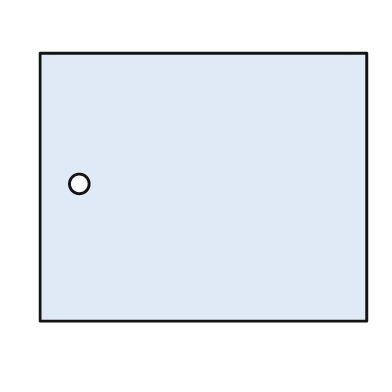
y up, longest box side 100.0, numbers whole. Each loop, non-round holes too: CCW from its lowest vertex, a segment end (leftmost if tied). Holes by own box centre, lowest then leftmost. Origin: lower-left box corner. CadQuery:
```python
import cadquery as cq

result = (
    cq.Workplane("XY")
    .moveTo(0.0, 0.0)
    .lineTo(100.0, 0.0)
    .lineTo(100.0, 82.0)
    .lineTo(0.0, 82.0)
    .close()
    .moveTo(12.0, 42.0)
    .circle(3.0)
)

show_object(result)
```